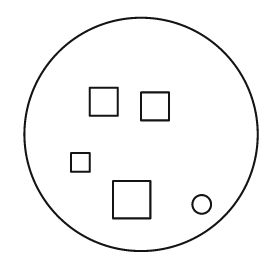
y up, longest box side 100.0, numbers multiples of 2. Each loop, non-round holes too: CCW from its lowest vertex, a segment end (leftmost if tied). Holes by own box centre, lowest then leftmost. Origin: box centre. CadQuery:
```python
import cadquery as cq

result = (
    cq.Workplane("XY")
    .moveTo(0.0, 0.0)
    .circle(50.0)
    .moveTo(26.0, -30.0)
    .circle(4.0)
    .moveTo(-12.0, -36.0)
    .lineTo(4.0, -36.0)
    .lineTo(4.0, -20.0)
    .lineTo(-12.0, -20.0)
    .close()
    .moveTo(-30.0, -16.0)
    .lineTo(-22.0, -16.0)
    .lineTo(-22.0, -8.0)
    .lineTo(-30.0, -8.0)
    .close()
    .moveTo(0.0, 6.0)
    .lineTo(12.0, 6.0)
    .lineTo(12.0, 18.0)
    .lineTo(0.0, 18.0)
    .close()
    .moveTo(-22.0, 8.0)
    .lineTo(-10.0, 8.0)
    .lineTo(-10.0, 20.0)
    .lineTo(-22.0, 20.0)
    .close()
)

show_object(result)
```